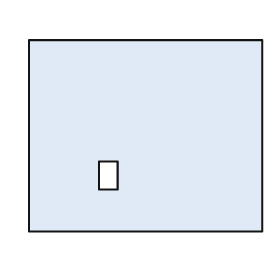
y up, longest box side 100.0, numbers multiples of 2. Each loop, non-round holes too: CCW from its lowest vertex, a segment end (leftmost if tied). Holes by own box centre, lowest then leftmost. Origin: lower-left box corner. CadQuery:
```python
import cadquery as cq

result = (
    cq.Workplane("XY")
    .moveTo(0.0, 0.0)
    .lineTo(100.0, 0.0)
    .lineTo(100.0, 82.0)
    .lineTo(0.0, 82.0)
    .close()
    .moveTo(30.0, 18.0)
    .lineTo(38.0, 18.0)
    .lineTo(38.0, 30.0)
    .lineTo(30.0, 30.0)
    .close()
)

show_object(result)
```